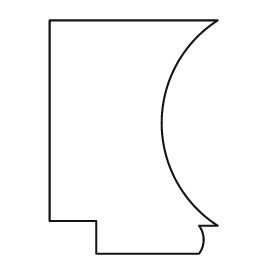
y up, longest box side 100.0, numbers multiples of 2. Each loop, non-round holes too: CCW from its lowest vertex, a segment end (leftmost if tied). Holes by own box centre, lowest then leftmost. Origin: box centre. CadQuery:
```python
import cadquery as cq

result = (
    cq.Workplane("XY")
    .moveTo(-16.0, -50.0)
    .lineTo(28.0, -50.0)
    .threePointArc((30.0, -44.0), (28.0, -38.0))
    .lineTo(36.0, -38.0)
    .threePointArc((12.0, 6.0), (36.0, 50.0))
    .lineTo(-36.0, 50.0)
    .lineTo(-36.0, -36.0)
    .lineTo(-16.0, -36.0)
    .close()
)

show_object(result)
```